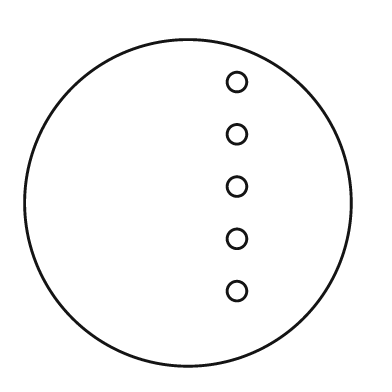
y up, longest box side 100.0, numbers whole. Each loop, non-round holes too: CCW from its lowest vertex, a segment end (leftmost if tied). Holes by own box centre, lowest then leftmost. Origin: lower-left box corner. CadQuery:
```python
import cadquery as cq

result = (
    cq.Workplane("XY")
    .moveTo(50.0, 50.0)
    .circle(50.0)
    .moveTo(65.0, 23.0)
    .circle(3.0)
    .moveTo(65.0, 39.0)
    .circle(3.0)
    .moveTo(65.0, 55.0)
    .circle(3.0)
    .moveTo(65.0, 71.0)
    .circle(3.0)
    .moveTo(65.0, 87.0)
    .circle(3.0)
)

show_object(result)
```